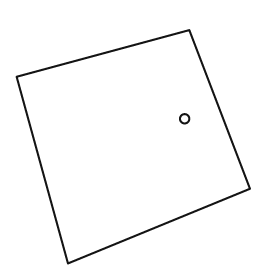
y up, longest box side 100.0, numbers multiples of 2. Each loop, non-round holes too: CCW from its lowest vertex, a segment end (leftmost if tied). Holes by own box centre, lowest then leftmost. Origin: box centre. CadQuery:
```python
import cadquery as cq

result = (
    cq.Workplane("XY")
    .moveTo(-28.0, -50.0)
    .lineTo(50.0, -18.0)
    .lineTo(24.0, 50.0)
    .lineTo(-50.0, 30.0)
    .close()
    .moveTo(22.0, 12.0)
    .circle(2.0)
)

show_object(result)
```